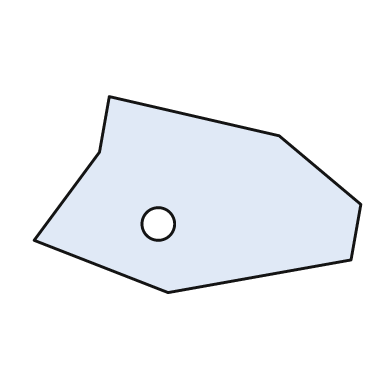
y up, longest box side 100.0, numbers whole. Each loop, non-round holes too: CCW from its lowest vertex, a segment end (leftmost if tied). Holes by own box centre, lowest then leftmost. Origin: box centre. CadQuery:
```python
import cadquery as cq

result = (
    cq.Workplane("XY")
    .moveTo(-9.0, -30.0)
    .lineTo(47.0, -20.0)
    .lineTo(50.0, -3.0)
    .lineTo(25.0, 18.0)
    .lineTo(-27.0, 30.0)
    .lineTo(-30.0, 13.0)
    .lineTo(-50.0, -14.0)
    .close()
    .moveTo(-12.0, -9.0)
    .circle(5.0)
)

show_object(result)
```